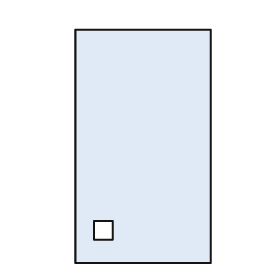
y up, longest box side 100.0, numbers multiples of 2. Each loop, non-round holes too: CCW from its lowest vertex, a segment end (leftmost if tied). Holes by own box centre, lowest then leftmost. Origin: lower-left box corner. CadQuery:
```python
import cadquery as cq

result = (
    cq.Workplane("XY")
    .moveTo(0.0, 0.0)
    .lineTo(58.0, 0.0)
    .lineTo(58.0, 100.0)
    .lineTo(0.0, 100.0)
    .close()
    .moveTo(8.0, 10.0)
    .lineTo(16.0, 10.0)
    .lineTo(16.0, 18.0)
    .lineTo(8.0, 18.0)
    .close()
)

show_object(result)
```